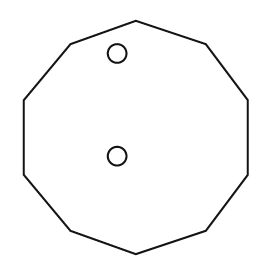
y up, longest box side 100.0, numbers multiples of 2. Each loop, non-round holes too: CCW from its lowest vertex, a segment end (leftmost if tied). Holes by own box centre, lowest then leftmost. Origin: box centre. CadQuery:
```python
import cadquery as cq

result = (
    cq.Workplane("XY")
    .moveTo(0.0, -50.0)
    .lineTo(30.0, -40.0)
    .lineTo(48.0, -16.0)
    .lineTo(48.0, 16.0)
    .lineTo(30.0, 40.0)
    .lineTo(0.0, 50.0)
    .lineTo(-28.0, 40.0)
    .lineTo(-48.0, 16.0)
    .lineTo(-48.0, -16.0)
    .lineTo(-28.0, -40.0)
    .close()
    .moveTo(-8.0, -8.0)
    .circle(4.0)
    .moveTo(-8.0, 36.0)
    .circle(4.0)
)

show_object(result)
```